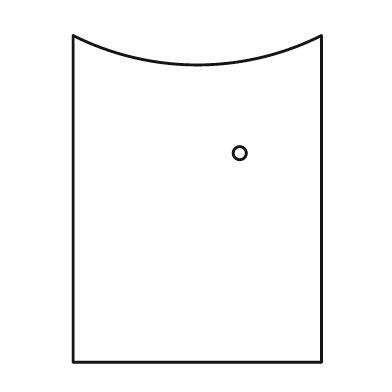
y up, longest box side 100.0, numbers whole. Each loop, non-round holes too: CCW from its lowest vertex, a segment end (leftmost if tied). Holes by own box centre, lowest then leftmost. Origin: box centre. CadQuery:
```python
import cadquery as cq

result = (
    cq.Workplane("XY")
    .moveTo(-38.0, -50.0)
    .lineTo(38.0, -50.0)
    .lineTo(38.0, 50.0)
    .threePointArc((0.0, 41.0), (-38.0, 50.0))
    .close()
    .moveTo(13.0, 14.0)
    .circle(2.0)
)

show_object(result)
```